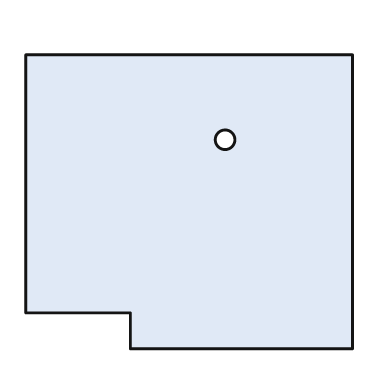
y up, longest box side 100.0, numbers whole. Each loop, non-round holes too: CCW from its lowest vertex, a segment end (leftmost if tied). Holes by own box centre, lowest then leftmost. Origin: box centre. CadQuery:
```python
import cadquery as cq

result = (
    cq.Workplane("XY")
    .moveTo(-18.0, -45.0)
    .lineTo(50.0, -45.0)
    .lineTo(50.0, 45.0)
    .lineTo(-50.0, 45.0)
    .lineTo(-50.0, -34.0)
    .lineTo(-18.0, -34.0)
    .close()
    .moveTo(11.0, 19.0)
    .circle(3.0)
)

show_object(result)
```